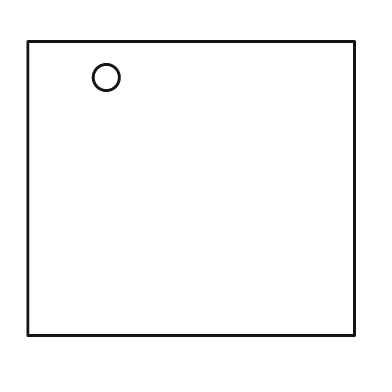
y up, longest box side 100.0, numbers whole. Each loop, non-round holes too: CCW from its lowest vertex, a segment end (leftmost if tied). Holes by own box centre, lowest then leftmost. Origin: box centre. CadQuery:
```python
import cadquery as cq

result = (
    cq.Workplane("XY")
    .moveTo(-50.0, -45.0)
    .lineTo(50.0, -45.0)
    .lineTo(50.0, 45.0)
    .lineTo(-50.0, 45.0)
    .close()
    .moveTo(-26.0, 34.0)
    .circle(4.0)
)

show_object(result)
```